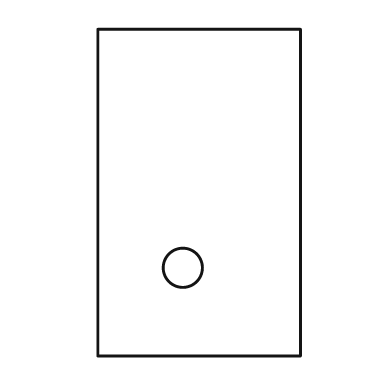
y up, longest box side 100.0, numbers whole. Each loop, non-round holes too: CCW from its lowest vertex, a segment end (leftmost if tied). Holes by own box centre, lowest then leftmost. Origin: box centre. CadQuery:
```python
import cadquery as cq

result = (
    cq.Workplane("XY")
    .moveTo(-31.0, -50.0)
    .lineTo(31.0, -50.0)
    .lineTo(31.0, 50.0)
    .lineTo(-31.0, 50.0)
    .close()
    .moveTo(-5.0, -23.0)
    .circle(6.0)
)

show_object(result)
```